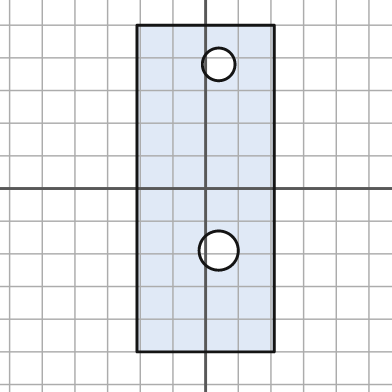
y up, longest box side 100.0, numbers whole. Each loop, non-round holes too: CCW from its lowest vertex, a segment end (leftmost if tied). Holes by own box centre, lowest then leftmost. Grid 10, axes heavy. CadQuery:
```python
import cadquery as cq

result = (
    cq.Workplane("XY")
    .moveTo(-21.0, -50.0)
    .lineTo(21.0, -50.0)
    .lineTo(21.0, 50.0)
    .lineTo(-21.0, 50.0)
    .close()
    .moveTo(4.0, -19.0)
    .circle(6.0)
    .moveTo(4.0, 38.0)
    .circle(5.0)
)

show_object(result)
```